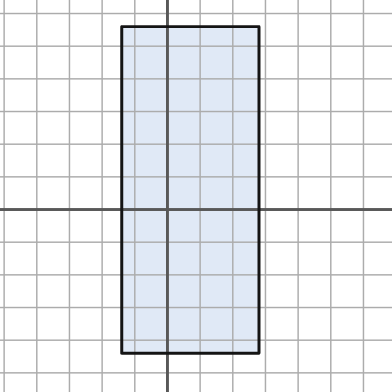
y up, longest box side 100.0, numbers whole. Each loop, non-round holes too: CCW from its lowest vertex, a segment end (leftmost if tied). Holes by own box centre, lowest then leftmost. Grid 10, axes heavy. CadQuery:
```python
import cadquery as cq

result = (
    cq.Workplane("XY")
    .moveTo(-14.0, -44.0)
    .lineTo(28.0, -44.0)
    .lineTo(28.0, 56.0)
    .lineTo(-14.0, 56.0)
    .close()
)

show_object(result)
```